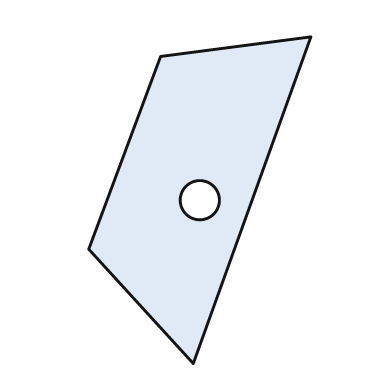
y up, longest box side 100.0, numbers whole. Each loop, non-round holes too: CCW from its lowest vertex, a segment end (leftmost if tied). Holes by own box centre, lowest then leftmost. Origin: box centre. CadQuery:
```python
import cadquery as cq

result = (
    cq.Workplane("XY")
    .moveTo(-2.0, -50.0)
    .lineTo(34.0, 50.0)
    .lineTo(-12.0, 44.0)
    .lineTo(-34.0, -15.0)
    .close()
    .moveTo(0.0, 0.0)
    .circle(6.0)
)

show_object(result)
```